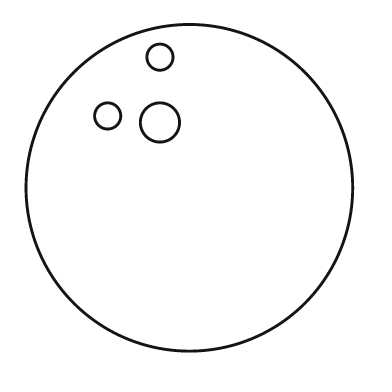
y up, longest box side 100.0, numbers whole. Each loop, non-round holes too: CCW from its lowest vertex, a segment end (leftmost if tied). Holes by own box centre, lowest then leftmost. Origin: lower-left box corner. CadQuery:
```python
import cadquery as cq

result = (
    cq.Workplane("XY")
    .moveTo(50.0, 50.0)
    .circle(50.0)
    .moveTo(41.0, 70.0)
    .circle(6.0)
    .moveTo(25.0, 72.0)
    .circle(4.0)
    .moveTo(41.0, 90.0)
    .circle(4.0)
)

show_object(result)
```